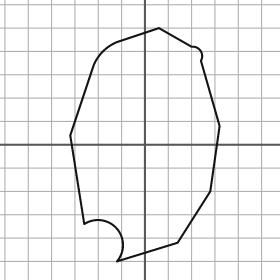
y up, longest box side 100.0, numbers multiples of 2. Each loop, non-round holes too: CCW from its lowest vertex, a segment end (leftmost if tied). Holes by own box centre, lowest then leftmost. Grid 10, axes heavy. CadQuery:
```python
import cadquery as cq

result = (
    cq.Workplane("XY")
    .moveTo(-12.0, -50.0)
    .lineTo(14.0, -42.0)
    .lineTo(28.0, -20.0)
    .lineTo(32.0, 8.0)
    .lineTo(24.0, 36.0)
    .threePointArc((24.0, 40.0), (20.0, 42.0))
    .lineTo(6.0, 50.0)
    .lineTo(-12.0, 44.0)
    .threePointArc((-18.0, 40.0), (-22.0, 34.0))
    .lineTo(-32.0, 4.0)
    .lineTo(-26.0, -34.0)
    .threePointArc((-12.0, -36.0), (-12.0, -50.0))
    .close()
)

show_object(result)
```